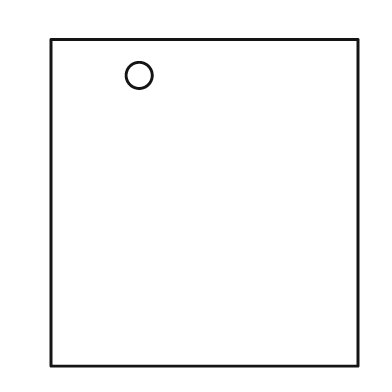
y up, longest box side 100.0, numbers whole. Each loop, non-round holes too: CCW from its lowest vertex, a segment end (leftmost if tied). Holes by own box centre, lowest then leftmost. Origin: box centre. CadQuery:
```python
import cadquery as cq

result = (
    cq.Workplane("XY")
    .moveTo(-47.0, -50.0)
    .lineTo(47.0, -50.0)
    .lineTo(47.0, 50.0)
    .lineTo(-47.0, 50.0)
    .close()
    .moveTo(-20.0, 39.0)
    .circle(4.0)
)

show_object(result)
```